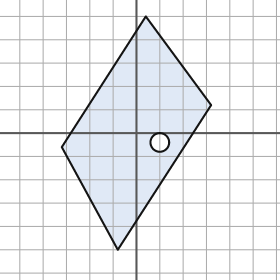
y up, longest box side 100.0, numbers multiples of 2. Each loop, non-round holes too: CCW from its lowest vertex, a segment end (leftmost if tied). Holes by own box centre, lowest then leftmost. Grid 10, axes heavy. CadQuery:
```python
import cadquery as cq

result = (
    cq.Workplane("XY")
    .moveTo(-8.0, -50.0)
    .lineTo(32.0, 12.0)
    .lineTo(4.0, 50.0)
    .lineTo(-32.0, -6.0)
    .close()
    .moveTo(10.0, -4.0)
    .circle(4.0)
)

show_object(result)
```